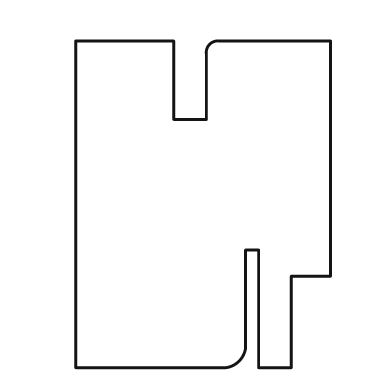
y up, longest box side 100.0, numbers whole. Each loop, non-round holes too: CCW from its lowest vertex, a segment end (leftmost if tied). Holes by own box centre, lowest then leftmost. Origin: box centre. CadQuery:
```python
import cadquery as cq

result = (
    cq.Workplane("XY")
    .moveTo(-39.0, -50.0)
    .lineTo(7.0, -50.0)
    .threePointArc((11.0, -48.0), (13.0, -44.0))
    .lineTo(13.0, -14.0)
    .lineTo(17.0, -14.0)
    .lineTo(17.0, -50.0)
    .lineTo(27.0, -50.0)
    .lineTo(27.0, -22.0)
    .lineTo(39.0, -22.0)
    .lineTo(39.0, 50.0)
    .lineTo(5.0, 50.0)
    .threePointArc((2.0, 49.0), (1.0, 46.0))
    .lineTo(1.0, 26.0)
    .lineTo(-9.0, 26.0)
    .lineTo(-9.0, 50.0)
    .lineTo(-39.0, 50.0)
    .close()
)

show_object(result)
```